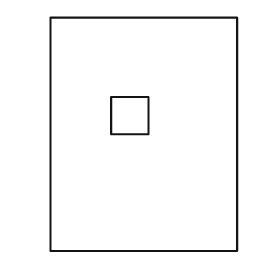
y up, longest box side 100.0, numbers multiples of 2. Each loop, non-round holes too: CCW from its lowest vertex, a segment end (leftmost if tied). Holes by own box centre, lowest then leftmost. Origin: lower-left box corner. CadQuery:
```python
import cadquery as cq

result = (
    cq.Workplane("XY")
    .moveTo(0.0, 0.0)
    .lineTo(80.0, 0.0)
    .lineTo(80.0, 100.0)
    .lineTo(0.0, 100.0)
    .close()
    .moveTo(26.0, 50.0)
    .lineTo(42.0, 50.0)
    .lineTo(42.0, 66.0)
    .lineTo(26.0, 66.0)
    .close()
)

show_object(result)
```